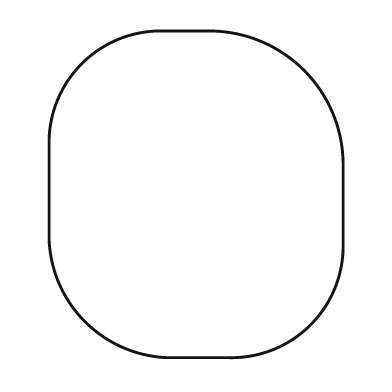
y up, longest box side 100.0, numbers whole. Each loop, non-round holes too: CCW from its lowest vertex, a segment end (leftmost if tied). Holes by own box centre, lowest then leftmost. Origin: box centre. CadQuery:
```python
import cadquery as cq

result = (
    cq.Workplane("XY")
    .moveTo(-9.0, -50.0)
    .lineTo(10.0, -50.0)
    .threePointArc((35.0, -40.0), (45.0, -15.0))
    .lineTo(45.0, 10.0)
    .threePointArc((33.0, 38.0), (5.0, 50.0))
    .lineTo(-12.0, 50.0)
    .threePointArc((-35.0, 40.0), (-45.0, 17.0))
    .lineTo(-45.0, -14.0)
    .threePointArc((-34.0, -39.0), (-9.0, -50.0))
    .close()
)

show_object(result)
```